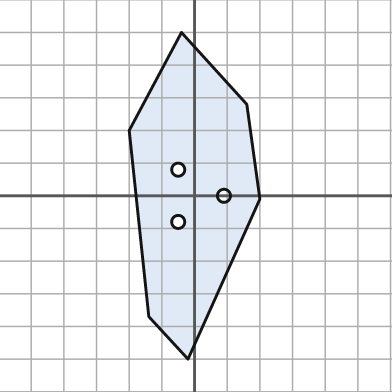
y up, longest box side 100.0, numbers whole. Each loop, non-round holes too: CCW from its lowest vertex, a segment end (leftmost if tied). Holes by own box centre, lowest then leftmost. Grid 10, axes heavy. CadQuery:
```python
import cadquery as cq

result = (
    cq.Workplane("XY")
    .moveTo(-2.0, -50.0)
    .lineTo(20.0, -1.0)
    .lineTo(16.0, 28.0)
    .lineTo(-4.0, 50.0)
    .lineTo(-20.0, 20.0)
    .lineTo(-14.0, -37.0)
    .close()
    .moveTo(-5.0, -8.0)
    .circle(2.0)
    .moveTo(9.0, 0.0)
    .circle(2.0)
    .moveTo(-5.0, 8.0)
    .circle(2.0)
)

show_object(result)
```